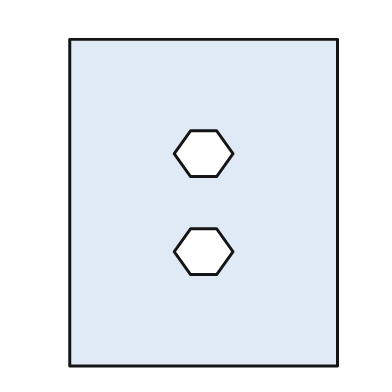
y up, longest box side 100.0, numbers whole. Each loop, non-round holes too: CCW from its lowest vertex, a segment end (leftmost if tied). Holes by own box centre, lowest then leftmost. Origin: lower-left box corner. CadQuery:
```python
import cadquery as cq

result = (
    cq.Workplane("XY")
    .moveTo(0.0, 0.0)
    .lineTo(82.0, 0.0)
    .lineTo(82.0, 100.0)
    .lineTo(0.0, 100.0)
    .close()
    .moveTo(37.0, 28.0)
    .lineTo(45.0, 28.0)
    .lineTo(50.0, 35.0)
    .lineTo(45.0, 42.0)
    .lineTo(37.0, 42.0)
    .lineTo(32.0, 35.0)
    .close()
    .moveTo(37.0, 58.0)
    .lineTo(45.0, 58.0)
    .lineTo(50.0, 65.0)
    .lineTo(45.0, 72.0)
    .lineTo(37.0, 72.0)
    .lineTo(32.0, 65.0)
    .close()
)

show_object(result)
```